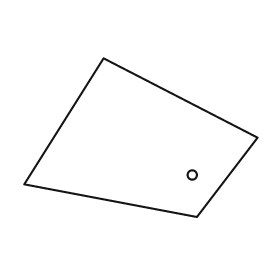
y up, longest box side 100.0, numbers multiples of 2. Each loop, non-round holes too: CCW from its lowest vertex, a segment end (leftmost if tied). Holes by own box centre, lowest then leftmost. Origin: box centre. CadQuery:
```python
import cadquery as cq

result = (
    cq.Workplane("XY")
    .moveTo(24.0, -34.0)
    .lineTo(50.0, 0.0)
    .lineTo(-16.0, 34.0)
    .lineTo(-50.0, -20.0)
    .close()
    .moveTo(22.0, -16.0)
    .circle(2.0)
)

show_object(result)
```